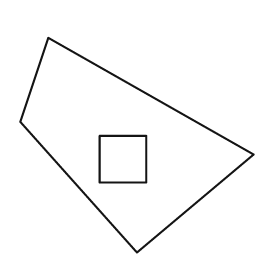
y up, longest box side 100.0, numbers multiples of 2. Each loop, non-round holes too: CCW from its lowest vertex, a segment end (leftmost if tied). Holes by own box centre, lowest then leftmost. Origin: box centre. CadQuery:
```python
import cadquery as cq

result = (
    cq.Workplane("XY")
    .moveTo(0.0, -46.0)
    .lineTo(50.0, -4.0)
    .lineTo(-38.0, 46.0)
    .lineTo(-50.0, 10.0)
    .close()
    .moveTo(-16.0, -16.0)
    .lineTo(4.0, -16.0)
    .lineTo(4.0, 4.0)
    .lineTo(-16.0, 4.0)
    .close()
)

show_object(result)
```